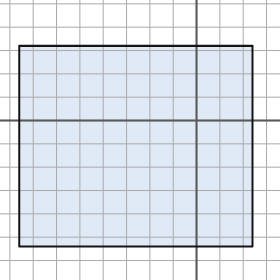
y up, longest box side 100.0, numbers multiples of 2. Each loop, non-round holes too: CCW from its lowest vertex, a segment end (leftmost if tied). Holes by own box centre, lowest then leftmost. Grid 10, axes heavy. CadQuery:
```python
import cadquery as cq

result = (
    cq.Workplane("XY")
    .moveTo(-76.0, -54.0)
    .lineTo(24.0, -54.0)
    .lineTo(24.0, 32.0)
    .lineTo(-76.0, 32.0)
    .close()
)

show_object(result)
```